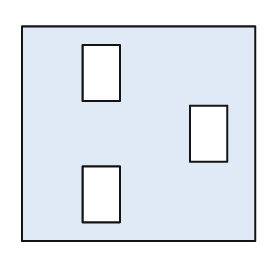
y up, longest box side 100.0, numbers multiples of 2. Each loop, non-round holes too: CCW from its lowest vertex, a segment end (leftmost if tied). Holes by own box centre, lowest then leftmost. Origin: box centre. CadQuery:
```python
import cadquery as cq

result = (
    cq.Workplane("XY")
    .moveTo(-50.0, -46.0)
    .lineTo(50.0, -46.0)
    .lineTo(50.0, 46.0)
    .lineTo(-50.0, 46.0)
    .close()
    .moveTo(-24.0, -38.0)
    .lineTo(-8.0, -38.0)
    .lineTo(-8.0, -14.0)
    .lineTo(-24.0, -14.0)
    .close()
    .moveTo(22.0, -12.0)
    .lineTo(38.0, -12.0)
    .lineTo(38.0, 12.0)
    .lineTo(22.0, 12.0)
    .close()
    .moveTo(-24.0, 14.0)
    .lineTo(-8.0, 14.0)
    .lineTo(-8.0, 38.0)
    .lineTo(-24.0, 38.0)
    .close()
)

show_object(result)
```